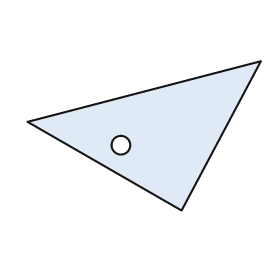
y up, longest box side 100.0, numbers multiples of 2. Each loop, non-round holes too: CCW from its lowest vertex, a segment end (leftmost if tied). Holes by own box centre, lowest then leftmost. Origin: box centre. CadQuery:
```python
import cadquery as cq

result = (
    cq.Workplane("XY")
    .moveTo(16.0, -32.0)
    .lineTo(50.0, 32.0)
    .lineTo(-50.0, 6.0)
    .close()
    .moveTo(-10.0, -4.0)
    .circle(4.0)
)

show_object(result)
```